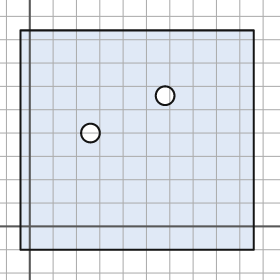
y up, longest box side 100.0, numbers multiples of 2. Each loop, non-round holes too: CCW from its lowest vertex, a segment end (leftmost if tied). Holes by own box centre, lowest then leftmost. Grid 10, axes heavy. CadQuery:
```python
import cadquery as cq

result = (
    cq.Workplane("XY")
    .moveTo(-4.0, -10.0)
    .lineTo(96.0, -10.0)
    .lineTo(96.0, 84.0)
    .lineTo(-4.0, 84.0)
    .close()
    .moveTo(26.0, 40.0)
    .circle(4.0)
    .moveTo(58.0, 56.0)
    .circle(4.0)
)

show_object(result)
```